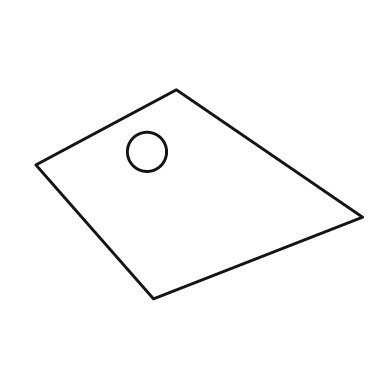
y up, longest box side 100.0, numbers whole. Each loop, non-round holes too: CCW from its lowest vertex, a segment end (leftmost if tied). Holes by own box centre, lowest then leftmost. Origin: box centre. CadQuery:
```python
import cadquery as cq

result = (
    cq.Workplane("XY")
    .moveTo(-14.0, -32.0)
    .lineTo(50.0, -7.0)
    .lineTo(-7.0, 32.0)
    .lineTo(-50.0, 9.0)
    .close()
    .moveTo(-16.0, 13.0)
    .circle(6.0)
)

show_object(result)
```